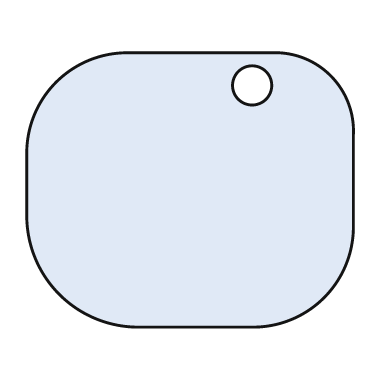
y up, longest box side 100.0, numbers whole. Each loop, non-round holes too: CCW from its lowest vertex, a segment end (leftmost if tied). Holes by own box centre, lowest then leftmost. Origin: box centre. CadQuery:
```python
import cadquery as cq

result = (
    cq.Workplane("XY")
    .moveTo(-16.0, -42.0)
    .lineTo(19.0, -42.0)
    .threePointArc((41.0, -33.0), (50.0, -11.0))
    .lineTo(50.0, 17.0)
    .threePointArc((43.0, 35.0), (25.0, 42.0))
    .lineTo(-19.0, 42.0)
    .threePointArc((-41.0, 33.0), (-50.0, 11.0))
    .lineTo(-50.0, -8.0)
    .threePointArc((-40.0, -32.0), (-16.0, -42.0))
    .close()
    .moveTo(19.0, 32.0)
    .circle(6.0)
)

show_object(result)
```